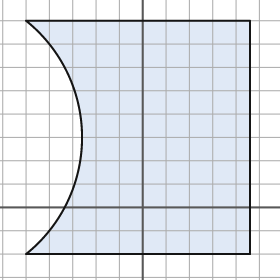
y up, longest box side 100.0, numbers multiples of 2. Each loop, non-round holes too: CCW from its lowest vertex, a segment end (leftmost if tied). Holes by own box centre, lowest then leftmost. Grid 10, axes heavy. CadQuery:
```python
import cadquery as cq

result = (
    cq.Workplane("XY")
    .moveTo(-50.0, -20.0)
    .lineTo(46.0, -20.0)
    .lineTo(46.0, 80.0)
    .lineTo(-50.0, 80.0)
    .threePointArc((-26.0, 30.0), (-50.0, -20.0))
    .close()
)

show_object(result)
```